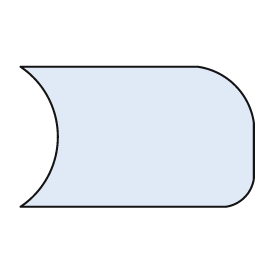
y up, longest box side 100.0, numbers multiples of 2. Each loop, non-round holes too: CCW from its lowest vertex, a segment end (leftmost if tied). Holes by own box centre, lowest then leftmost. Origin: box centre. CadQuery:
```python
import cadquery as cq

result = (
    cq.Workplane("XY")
    .moveTo(-50.0, -30.0)
    .lineTo(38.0, -30.0)
    .threePointArc((46.0, -26.0), (50.0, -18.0))
    .lineTo(50.0, 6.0)
    .threePointArc((42.0, 22.0), (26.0, 30.0))
    .lineTo(-50.0, 30.0)
    .threePointArc((-34.0, 0.0), (-50.0, -30.0))
    .close()
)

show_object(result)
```